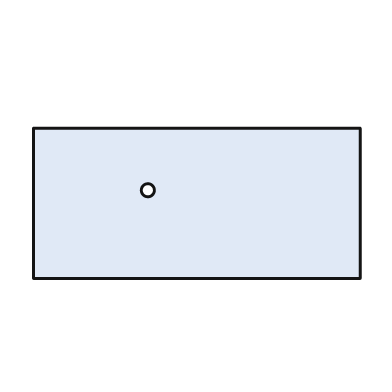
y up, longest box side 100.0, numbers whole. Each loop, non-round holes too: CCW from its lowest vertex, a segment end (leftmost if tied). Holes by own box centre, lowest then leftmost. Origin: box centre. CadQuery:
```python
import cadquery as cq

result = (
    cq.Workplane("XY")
    .moveTo(-50.0, -23.0)
    .lineTo(50.0, -23.0)
    .lineTo(50.0, 23.0)
    .lineTo(-50.0, 23.0)
    .close()
    .moveTo(-15.0, 4.0)
    .circle(2.0)
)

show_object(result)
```